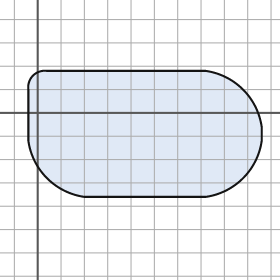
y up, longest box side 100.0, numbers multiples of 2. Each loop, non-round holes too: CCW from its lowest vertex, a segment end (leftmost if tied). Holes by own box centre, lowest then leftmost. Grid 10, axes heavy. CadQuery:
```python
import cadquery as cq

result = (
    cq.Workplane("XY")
    .moveTo(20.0, -36.0)
    .lineTo(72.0, -36.0)
    .threePointArc((88.0, -28.0), (96.0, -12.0))
    .lineTo(96.0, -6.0)
    .threePointArc((88.0, 10.0), (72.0, 18.0))
    .lineTo(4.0, 18.0)
    .threePointArc((-2.0, 16.0), (-4.0, 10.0))
    .lineTo(-4.0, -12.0)
    .threePointArc((4.0, -28.0), (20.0, -36.0))
    .close()
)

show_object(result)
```